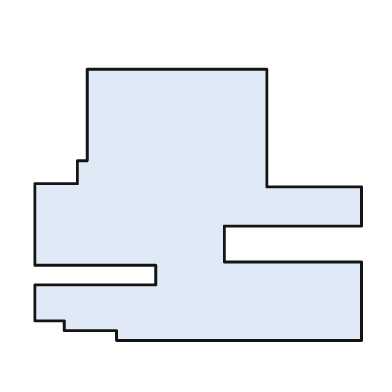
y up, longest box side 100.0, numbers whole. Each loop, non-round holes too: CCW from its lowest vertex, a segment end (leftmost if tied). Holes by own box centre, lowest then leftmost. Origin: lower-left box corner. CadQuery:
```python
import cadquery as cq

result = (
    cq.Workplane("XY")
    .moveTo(25.0, 0.0)
    .lineTo(100.0, 0.0)
    .lineTo(100.0, 24.0)
    .lineTo(58.0, 24.0)
    .lineTo(58.0, 35.0)
    .lineTo(100.0, 35.0)
    .lineTo(100.0, 47.0)
    .lineTo(71.0, 47.0)
    .lineTo(71.0, 83.0)
    .lineTo(16.0, 83.0)
    .lineTo(16.0, 55.0)
    .lineTo(13.0, 55.0)
    .lineTo(13.0, 48.0)
    .lineTo(0.0, 48.0)
    .lineTo(0.0, 23.0)
    .lineTo(37.0, 23.0)
    .lineTo(37.0, 17.0)
    .lineTo(0.0, 17.0)
    .lineTo(0.0, 6.0)
    .lineTo(9.0, 6.0)
    .lineTo(9.0, 3.0)
    .lineTo(25.0, 3.0)
    .close()
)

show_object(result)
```